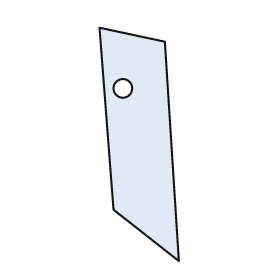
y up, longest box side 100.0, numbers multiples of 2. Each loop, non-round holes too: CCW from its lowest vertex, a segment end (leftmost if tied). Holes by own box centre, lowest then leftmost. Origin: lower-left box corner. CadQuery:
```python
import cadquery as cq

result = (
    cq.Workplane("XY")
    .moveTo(34.0, 0.0)
    .lineTo(28.0, 94.0)
    .lineTo(0.0, 100.0)
    .lineTo(6.0, 22.0)
    .close()
    .moveTo(10.0, 74.0)
    .circle(4.0)
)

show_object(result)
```